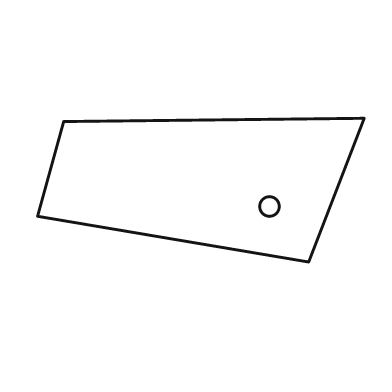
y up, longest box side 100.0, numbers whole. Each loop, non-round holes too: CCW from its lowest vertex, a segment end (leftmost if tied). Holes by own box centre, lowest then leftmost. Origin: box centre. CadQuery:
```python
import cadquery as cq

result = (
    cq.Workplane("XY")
    .moveTo(33.0, -22.0)
    .lineTo(50.0, 22.0)
    .lineTo(-42.0, 21.0)
    .lineTo(-50.0, -8.0)
    .close()
    .moveTo(21.0, -5.0)
    .circle(3.0)
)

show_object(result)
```